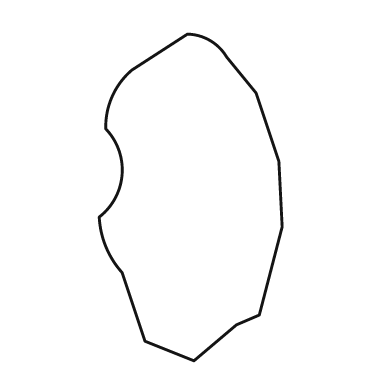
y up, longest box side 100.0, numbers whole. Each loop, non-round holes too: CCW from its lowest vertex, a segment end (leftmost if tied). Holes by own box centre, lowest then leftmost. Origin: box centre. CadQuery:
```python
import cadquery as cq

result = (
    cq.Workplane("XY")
    .moveTo(1.0, -50.0)
    .lineTo(14.0, -39.0)
    .lineTo(21.0, -36.0)
    .lineTo(28.0, -9.0)
    .lineTo(27.0, 11.0)
    .lineTo(20.0, 32.0)
    .lineTo(11.0, 43.0)
    .threePointArc((6.0, 48.0), (-1.0, 50.0))
    .lineTo(-18.0, 39.0)
    .threePointArc((-24.0, 31.0), (-26.0, 21.0))
    .threePointArc((-21.0, 7.0), (-28.0, -6.0))
    .threePointArc((-26.0, -15.0), (-21.0, -23.0))
    .lineTo(-14.0, -44.0)
    .close()
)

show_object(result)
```